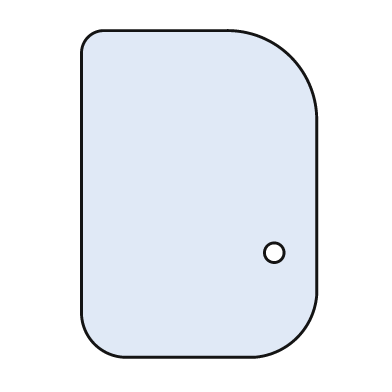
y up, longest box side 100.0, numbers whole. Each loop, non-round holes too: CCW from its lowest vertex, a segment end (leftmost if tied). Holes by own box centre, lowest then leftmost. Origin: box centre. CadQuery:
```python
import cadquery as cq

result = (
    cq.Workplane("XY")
    .moveTo(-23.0, -50.0)
    .lineTo(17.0, -50.0)
    .threePointArc((30.0, -44.0), (36.0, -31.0))
    .lineTo(36.0, 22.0)
    .threePointArc((28.0, 42.0), (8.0, 50.0))
    .lineTo(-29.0, 50.0)
    .threePointArc((-34.0, 48.0), (-36.0, 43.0))
    .lineTo(-36.0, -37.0)
    .threePointArc((-32.0, -46.0), (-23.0, -50.0))
    .close()
    .moveTo(23.0, -18.0)
    .circle(3.0)
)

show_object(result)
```